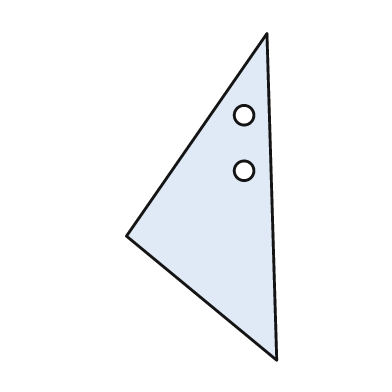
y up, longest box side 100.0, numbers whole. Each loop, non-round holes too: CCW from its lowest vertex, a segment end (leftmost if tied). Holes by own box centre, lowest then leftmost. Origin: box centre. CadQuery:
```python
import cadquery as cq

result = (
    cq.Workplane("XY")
    .moveTo(23.0, -50.0)
    .lineTo(20.0, 50.0)
    .lineTo(-23.0, -12.0)
    .close()
    .moveTo(13.0, 8.0)
    .circle(3.0)
    .moveTo(13.0, 25.0)
    .circle(3.0)
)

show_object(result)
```